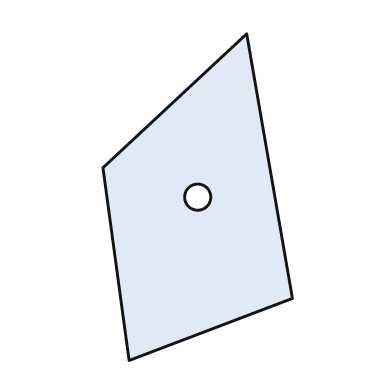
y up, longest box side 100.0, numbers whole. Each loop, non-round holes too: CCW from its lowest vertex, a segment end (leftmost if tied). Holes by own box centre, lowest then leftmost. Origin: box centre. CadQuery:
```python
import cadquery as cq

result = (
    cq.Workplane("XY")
    .moveTo(-21.0, -50.0)
    .lineTo(29.0, -31.0)
    .lineTo(15.0, 50.0)
    .lineTo(-29.0, 9.0)
    .close()
    .moveTo(0.0, 0.0)
    .circle(4.0)
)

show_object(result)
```